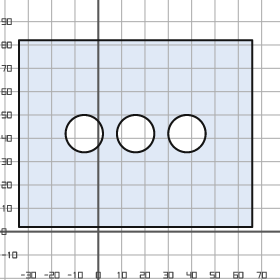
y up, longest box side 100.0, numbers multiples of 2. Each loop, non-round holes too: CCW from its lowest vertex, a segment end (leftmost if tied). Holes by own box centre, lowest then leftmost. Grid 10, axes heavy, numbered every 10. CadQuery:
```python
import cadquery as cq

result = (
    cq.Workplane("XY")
    .moveTo(-34.0, 2.0)
    .lineTo(66.0, 2.0)
    .lineTo(66.0, 82.0)
    .lineTo(-34.0, 82.0)
    .close()
    .moveTo(-6.0, 42.0)
    .circle(8.0)
    .moveTo(16.0, 42.0)
    .circle(8.0)
    .moveTo(38.0, 42.0)
    .circle(8.0)
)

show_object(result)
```